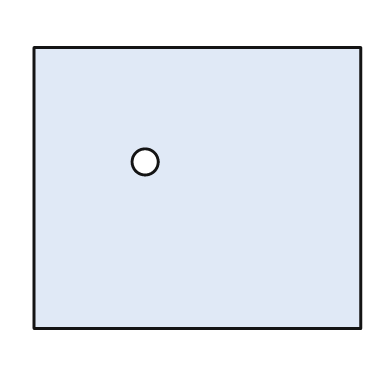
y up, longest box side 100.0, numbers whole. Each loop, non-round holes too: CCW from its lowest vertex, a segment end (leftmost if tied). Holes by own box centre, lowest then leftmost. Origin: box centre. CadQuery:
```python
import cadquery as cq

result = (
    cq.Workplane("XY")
    .moveTo(-50.0, -43.0)
    .lineTo(50.0, -43.0)
    .lineTo(50.0, 43.0)
    .lineTo(-50.0, 43.0)
    .close()
    .moveTo(-16.0, 8.0)
    .circle(4.0)
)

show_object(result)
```